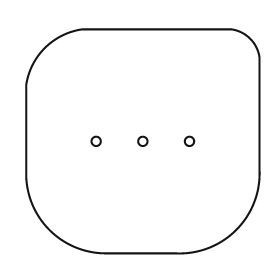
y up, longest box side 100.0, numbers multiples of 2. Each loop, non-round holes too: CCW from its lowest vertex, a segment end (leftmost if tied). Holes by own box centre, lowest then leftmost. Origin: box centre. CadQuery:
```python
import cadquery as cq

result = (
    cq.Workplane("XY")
    .moveTo(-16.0, -48.0)
    .lineTo(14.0, -48.0)
    .threePointArc((40.0, -38.0), (50.0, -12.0))
    .lineTo(50.0, 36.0)
    .threePointArc((46.0, 44.0), (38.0, 48.0))
    .lineTo(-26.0, 48.0)
    .threePointArc((-42.0, 40.0), (-50.0, 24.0))
    .lineTo(-50.0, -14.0)
    .threePointArc((-40.0, -38.0), (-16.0, -48.0))
    .close()
    .moveTo(-20.0, 0.0)
    .circle(2.0)
    .moveTo(0.0, 0.0)
    .circle(2.0)
    .moveTo(20.0, 0.0)
    .circle(2.0)
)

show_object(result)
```